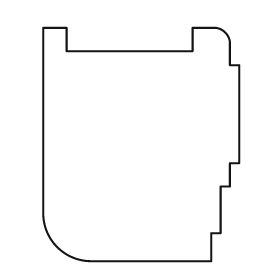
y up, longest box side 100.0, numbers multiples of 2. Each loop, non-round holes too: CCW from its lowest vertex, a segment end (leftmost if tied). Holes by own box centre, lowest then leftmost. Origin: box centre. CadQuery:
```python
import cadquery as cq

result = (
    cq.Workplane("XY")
    .moveTo(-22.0, -50.0)
    .lineTo(30.0, -50.0)
    .lineTo(30.0, -38.0)
    .lineTo(34.0, -38.0)
    .lineTo(34.0, -18.0)
    .lineTo(38.0, -18.0)
    .lineTo(38.0, -8.0)
    .lineTo(42.0, -8.0)
    .lineTo(42.0, 34.0)
    .lineTo(38.0, 34.0)
    .lineTo(38.0, 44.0)
    .threePointArc((36.0, 48.0), (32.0, 50.0))
    .lineTo(22.0, 50.0)
    .lineTo(22.0, 40.0)
    .lineTo(-32.0, 40.0)
    .lineTo(-32.0, 50.0)
    .lineTo(-42.0, 50.0)
    .lineTo(-42.0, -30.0)
    .threePointArc((-36.0, -44.0), (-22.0, -50.0))
    .close()
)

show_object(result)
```